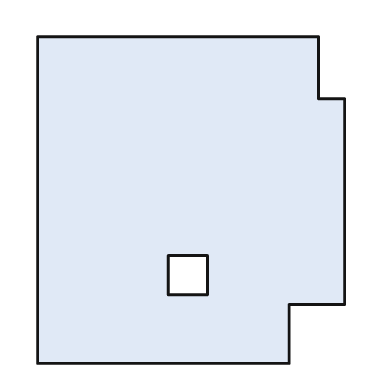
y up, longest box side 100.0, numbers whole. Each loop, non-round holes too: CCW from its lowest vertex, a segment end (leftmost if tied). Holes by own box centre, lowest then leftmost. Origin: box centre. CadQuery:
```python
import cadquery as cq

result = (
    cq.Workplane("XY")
    .moveTo(-47.0, -50.0)
    .lineTo(30.0, -50.0)
    .lineTo(30.0, -32.0)
    .lineTo(47.0, -32.0)
    .lineTo(47.0, 31.0)
    .lineTo(39.0, 31.0)
    .lineTo(39.0, 50.0)
    .lineTo(-47.0, 50.0)
    .close()
    .moveTo(-7.0, -29.0)
    .lineTo(5.0, -29.0)
    .lineTo(5.0, -17.0)
    .lineTo(-7.0, -17.0)
    .close()
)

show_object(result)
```